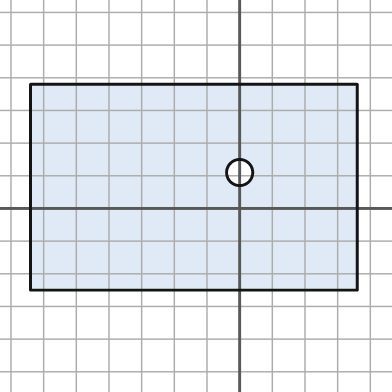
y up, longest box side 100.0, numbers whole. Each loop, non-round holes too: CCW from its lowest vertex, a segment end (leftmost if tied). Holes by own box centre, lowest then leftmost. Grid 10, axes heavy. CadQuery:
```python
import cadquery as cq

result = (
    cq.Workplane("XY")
    .moveTo(-64.0, -25.0)
    .lineTo(36.0, -25.0)
    .lineTo(36.0, 38.0)
    .lineTo(-64.0, 38.0)
    .close()
    .moveTo(0.0, 11.0)
    .circle(4.0)
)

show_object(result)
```